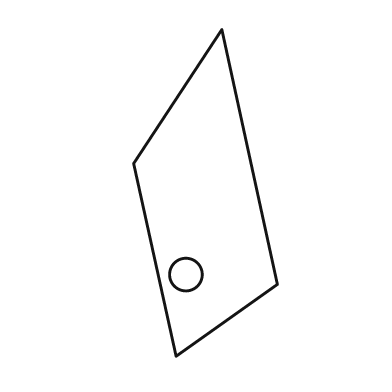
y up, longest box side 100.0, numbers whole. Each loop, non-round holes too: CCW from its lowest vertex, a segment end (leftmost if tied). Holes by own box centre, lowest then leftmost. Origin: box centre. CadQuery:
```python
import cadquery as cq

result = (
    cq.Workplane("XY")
    .moveTo(-9.0, -50.0)
    .lineTo(22.0, -28.0)
    .lineTo(5.0, 50.0)
    .lineTo(-22.0, 9.0)
    .close()
    .moveTo(-6.0, -25.0)
    .circle(5.0)
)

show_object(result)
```